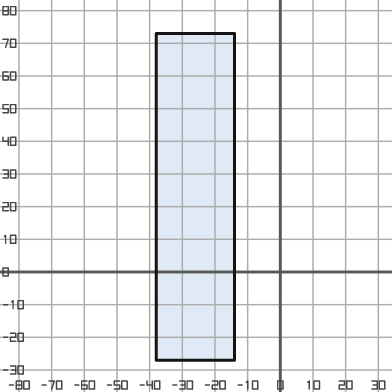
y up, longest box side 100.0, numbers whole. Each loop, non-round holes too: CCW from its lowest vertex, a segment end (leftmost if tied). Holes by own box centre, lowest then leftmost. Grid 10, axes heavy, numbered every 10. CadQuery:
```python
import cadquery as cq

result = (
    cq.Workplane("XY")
    .moveTo(-38.0, -27.0)
    .lineTo(-14.0, -27.0)
    .lineTo(-14.0, 73.0)
    .lineTo(-38.0, 73.0)
    .close()
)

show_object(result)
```